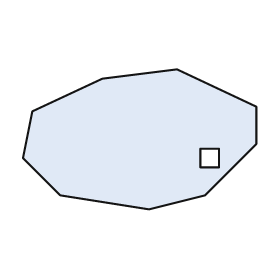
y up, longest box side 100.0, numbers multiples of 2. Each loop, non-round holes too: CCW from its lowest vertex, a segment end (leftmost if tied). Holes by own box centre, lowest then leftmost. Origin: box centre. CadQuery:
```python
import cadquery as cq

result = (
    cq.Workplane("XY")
    .moveTo(4.0, -30.0)
    .lineTo(28.0, -24.0)
    .lineTo(50.0, -2.0)
    .lineTo(50.0, 14.0)
    .lineTo(16.0, 30.0)
    .lineTo(-16.0, 26.0)
    .lineTo(-46.0, 12.0)
    .lineTo(-50.0, -8.0)
    .lineTo(-34.0, -24.0)
    .close()
    .moveTo(26.0, -12.0)
    .lineTo(34.0, -12.0)
    .lineTo(34.0, -4.0)
    .lineTo(26.0, -4.0)
    .close()
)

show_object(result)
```